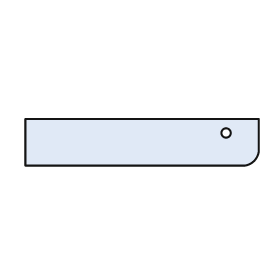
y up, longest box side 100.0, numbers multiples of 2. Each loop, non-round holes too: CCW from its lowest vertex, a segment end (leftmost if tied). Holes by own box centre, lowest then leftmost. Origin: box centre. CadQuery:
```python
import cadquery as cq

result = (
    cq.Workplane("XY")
    .moveTo(-50.0, -10.0)
    .lineTo(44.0, -10.0)
    .threePointArc((48.0, -8.0), (50.0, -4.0))
    .lineTo(50.0, 10.0)
    .lineTo(-50.0, 10.0)
    .close()
    .moveTo(36.0, 4.0)
    .circle(2.0)
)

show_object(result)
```